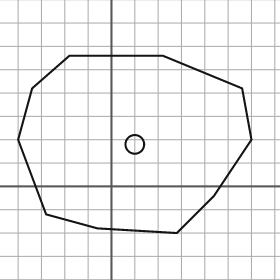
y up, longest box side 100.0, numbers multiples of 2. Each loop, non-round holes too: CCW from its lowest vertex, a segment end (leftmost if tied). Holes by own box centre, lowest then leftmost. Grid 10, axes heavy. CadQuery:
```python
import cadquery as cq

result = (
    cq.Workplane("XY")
    .moveTo(28.0, -20.0)
    .lineTo(44.0, -4.0)
    .lineTo(60.0, 20.0)
    .lineTo(56.0, 42.0)
    .lineTo(22.0, 56.0)
    .lineTo(-18.0, 56.0)
    .lineTo(-34.0, 42.0)
    .lineTo(-40.0, 20.0)
    .lineTo(-28.0, -12.0)
    .lineTo(-6.0, -18.0)
    .close()
    .moveTo(10.0, 18.0)
    .circle(4.0)
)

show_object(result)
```